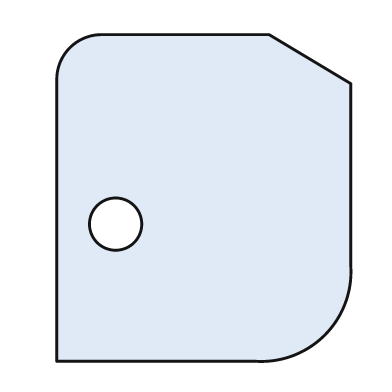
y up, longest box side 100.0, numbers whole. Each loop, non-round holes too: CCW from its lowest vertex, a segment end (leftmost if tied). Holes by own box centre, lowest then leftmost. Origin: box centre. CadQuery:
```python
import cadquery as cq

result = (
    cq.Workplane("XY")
    .moveTo(-45.0, -50.0)
    .lineTo(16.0, -50.0)
    .threePointArc((37.0, -42.0), (45.0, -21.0))
    .lineTo(45.0, 35.0)
    .lineTo(20.0, 50.0)
    .lineTo(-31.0, 50.0)
    .threePointArc((-41.0, 46.0), (-45.0, 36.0))
    .close()
    .moveTo(-27.0, -8.0)
    .circle(8.0)
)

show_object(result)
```